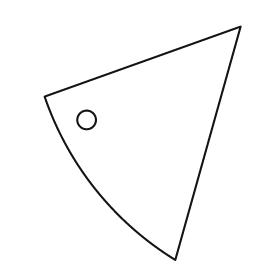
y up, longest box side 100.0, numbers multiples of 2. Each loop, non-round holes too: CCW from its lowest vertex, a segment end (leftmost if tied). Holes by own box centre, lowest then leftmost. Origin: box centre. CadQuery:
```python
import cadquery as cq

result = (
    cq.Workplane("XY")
    .moveTo(14.0, -50.0)
    .lineTo(42.0, 50.0)
    .lineTo(-42.0, 20.0)
    .threePointArc((-20.0, -20.0), (14.0, -50.0))
    .close()
    .moveTo(-24.0, 10.0)
    .circle(4.0)
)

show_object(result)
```